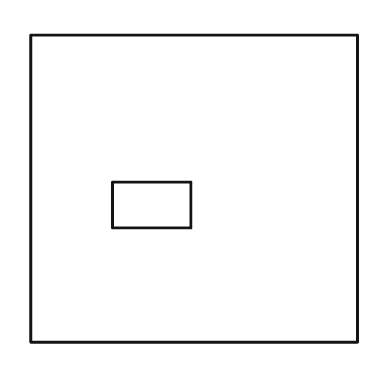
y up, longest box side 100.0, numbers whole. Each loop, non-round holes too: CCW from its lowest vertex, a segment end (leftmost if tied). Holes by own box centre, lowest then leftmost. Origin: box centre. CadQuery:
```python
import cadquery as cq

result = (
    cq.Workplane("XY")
    .moveTo(-50.0, -47.0)
    .lineTo(50.0, -47.0)
    .lineTo(50.0, 47.0)
    .lineTo(-50.0, 47.0)
    .close()
    .moveTo(-25.0, -12.0)
    .lineTo(-1.0, -12.0)
    .lineTo(-1.0, 2.0)
    .lineTo(-25.0, 2.0)
    .close()
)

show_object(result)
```